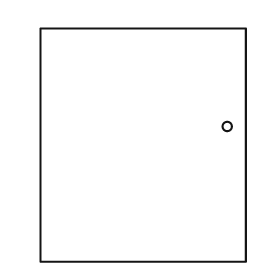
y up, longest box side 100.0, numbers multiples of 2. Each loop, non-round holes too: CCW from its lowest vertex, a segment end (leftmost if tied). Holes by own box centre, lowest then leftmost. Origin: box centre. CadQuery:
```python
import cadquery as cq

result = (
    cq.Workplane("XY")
    .moveTo(-44.0, -50.0)
    .lineTo(44.0, -50.0)
    .lineTo(44.0, 50.0)
    .lineTo(-44.0, 50.0)
    .close()
    .moveTo(36.0, 8.0)
    .circle(2.0)
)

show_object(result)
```